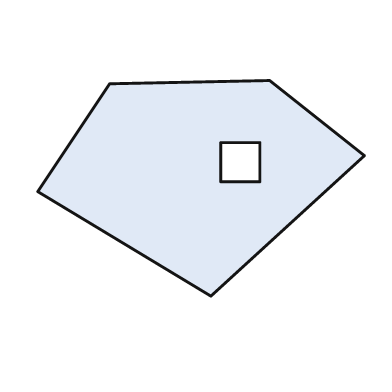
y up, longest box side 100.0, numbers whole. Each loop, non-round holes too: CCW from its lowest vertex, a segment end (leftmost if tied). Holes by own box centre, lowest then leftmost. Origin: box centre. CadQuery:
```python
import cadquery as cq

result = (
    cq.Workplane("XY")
    .moveTo(3.0, -33.0)
    .lineTo(50.0, 10.0)
    .lineTo(21.0, 33.0)
    .lineTo(-28.0, 32.0)
    .lineTo(-50.0, -1.0)
    .close()
    .moveTo(6.0, 2.0)
    .lineTo(18.0, 2.0)
    .lineTo(18.0, 14.0)
    .lineTo(6.0, 14.0)
    .close()
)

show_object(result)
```